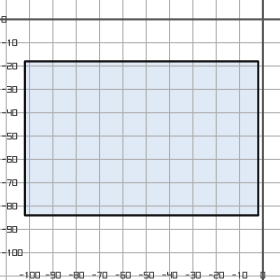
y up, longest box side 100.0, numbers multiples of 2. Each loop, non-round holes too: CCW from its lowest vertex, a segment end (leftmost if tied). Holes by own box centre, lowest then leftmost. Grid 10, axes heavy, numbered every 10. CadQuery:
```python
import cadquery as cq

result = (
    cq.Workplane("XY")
    .moveTo(-102.0, -84.0)
    .lineTo(-2.0, -84.0)
    .lineTo(-2.0, -18.0)
    .lineTo(-102.0, -18.0)
    .close()
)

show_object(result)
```